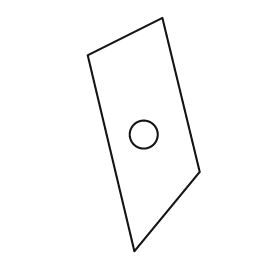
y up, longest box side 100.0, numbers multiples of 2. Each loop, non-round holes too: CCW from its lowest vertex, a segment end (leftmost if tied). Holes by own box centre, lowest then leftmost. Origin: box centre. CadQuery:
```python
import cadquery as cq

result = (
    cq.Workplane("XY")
    .moveTo(-4.0, -50.0)
    .lineTo(24.0, -16.0)
    .lineTo(8.0, 50.0)
    .lineTo(-24.0, 34.0)
    .close()
    .moveTo(0.0, 0.0)
    .circle(6.0)
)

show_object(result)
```